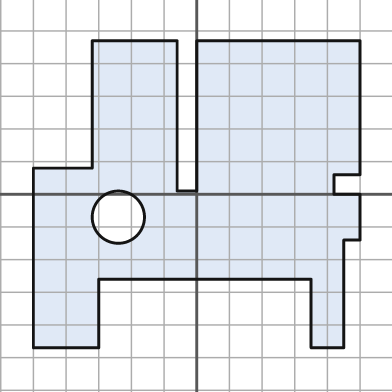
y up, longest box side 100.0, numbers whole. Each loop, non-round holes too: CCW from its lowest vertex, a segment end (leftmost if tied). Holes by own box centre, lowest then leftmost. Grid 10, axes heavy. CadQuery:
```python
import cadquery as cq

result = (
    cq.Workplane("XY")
    .moveTo(-50.0, -47.0)
    .lineTo(-30.0, -47.0)
    .lineTo(-30.0, -26.0)
    .lineTo(35.0, -26.0)
    .lineTo(35.0, -47.0)
    .lineTo(45.0, -47.0)
    .lineTo(45.0, -14.0)
    .lineTo(50.0, -14.0)
    .lineTo(50.0, 0.0)
    .lineTo(42.0, 0.0)
    .lineTo(42.0, 6.0)
    .lineTo(50.0, 6.0)
    .lineTo(50.0, 47.0)
    .lineTo(0.0, 47.0)
    .lineTo(0.0, 1.0)
    .lineTo(-6.0, 1.0)
    .lineTo(-6.0, 47.0)
    .lineTo(-32.0, 47.0)
    .lineTo(-32.0, 8.0)
    .lineTo(-50.0, 8.0)
    .close()
    .moveTo(-24.0, -7.0)
    .circle(8.0)
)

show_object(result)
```